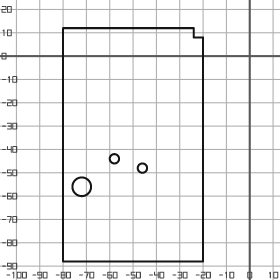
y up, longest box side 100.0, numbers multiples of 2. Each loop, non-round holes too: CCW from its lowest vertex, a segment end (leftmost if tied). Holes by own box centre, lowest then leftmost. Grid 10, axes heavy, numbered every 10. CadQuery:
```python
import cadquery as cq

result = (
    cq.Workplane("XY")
    .moveTo(-80.0, -88.0)
    .lineTo(-20.0, -88.0)
    .lineTo(-20.0, 8.0)
    .lineTo(-24.0, 8.0)
    .lineTo(-24.0, 12.0)
    .lineTo(-80.0, 12.0)
    .close()
    .moveTo(-72.0, -56.0)
    .circle(4.0)
    .moveTo(-46.0, -48.0)
    .circle(2.0)
    .moveTo(-58.0, -44.0)
    .circle(2.0)
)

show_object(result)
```